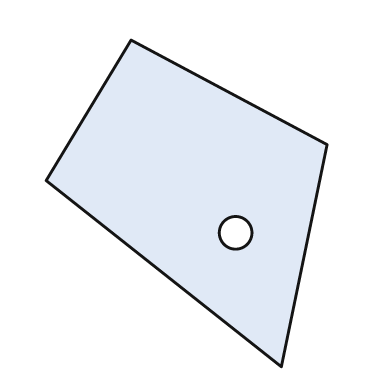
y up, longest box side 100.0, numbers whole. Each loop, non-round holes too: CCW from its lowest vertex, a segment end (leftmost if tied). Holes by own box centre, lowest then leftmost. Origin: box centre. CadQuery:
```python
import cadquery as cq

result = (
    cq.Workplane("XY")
    .moveTo(29.0, -50.0)
    .lineTo(43.0, 18.0)
    .lineTo(-17.0, 50.0)
    .lineTo(-43.0, 7.0)
    .close()
    .moveTo(15.0, -9.0)
    .circle(5.0)
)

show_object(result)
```